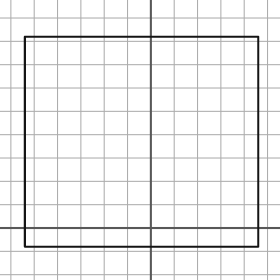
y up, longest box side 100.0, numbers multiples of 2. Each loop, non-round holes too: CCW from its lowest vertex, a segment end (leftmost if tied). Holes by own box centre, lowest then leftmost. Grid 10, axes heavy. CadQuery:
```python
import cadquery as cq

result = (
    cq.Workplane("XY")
    .moveTo(-54.0, -8.0)
    .lineTo(46.0, -8.0)
    .lineTo(46.0, 82.0)
    .lineTo(-54.0, 82.0)
    .close()
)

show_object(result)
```